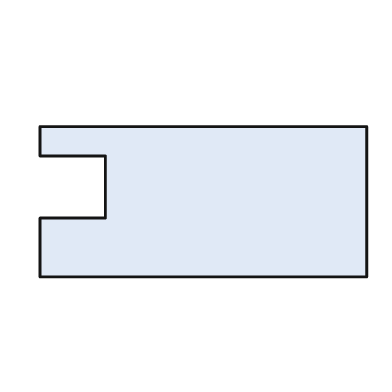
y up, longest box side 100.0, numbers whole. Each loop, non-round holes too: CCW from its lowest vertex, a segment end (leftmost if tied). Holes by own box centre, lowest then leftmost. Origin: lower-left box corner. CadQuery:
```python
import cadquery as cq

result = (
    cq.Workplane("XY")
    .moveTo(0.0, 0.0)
    .lineTo(100.0, 0.0)
    .lineTo(100.0, 46.0)
    .lineTo(0.0, 46.0)
    .lineTo(0.0, 37.0)
    .lineTo(20.0, 37.0)
    .lineTo(20.0, 18.0)
    .lineTo(0.0, 18.0)
    .close()
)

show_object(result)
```